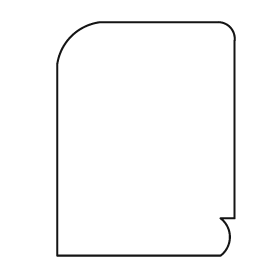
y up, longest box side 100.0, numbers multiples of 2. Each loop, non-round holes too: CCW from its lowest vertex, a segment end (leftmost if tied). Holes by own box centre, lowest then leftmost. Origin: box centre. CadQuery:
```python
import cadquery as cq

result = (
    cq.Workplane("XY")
    .moveTo(-38.0, -50.0)
    .lineTo(32.0, -50.0)
    .threePointArc((36.0, -42.0), (32.0, -34.0))
    .lineTo(38.0, -34.0)
    .lineTo(38.0, 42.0)
    .threePointArc((36.0, 48.0), (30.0, 50.0))
    .lineTo(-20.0, 50.0)
    .threePointArc((-32.0, 44.0), (-38.0, 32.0))
    .close()
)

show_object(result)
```